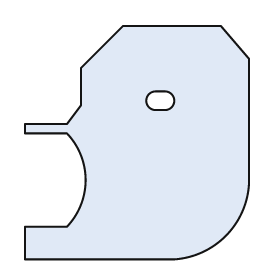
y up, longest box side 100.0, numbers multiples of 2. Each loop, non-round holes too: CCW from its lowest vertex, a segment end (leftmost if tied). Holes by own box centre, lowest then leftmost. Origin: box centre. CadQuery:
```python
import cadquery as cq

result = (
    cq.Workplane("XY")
    .moveTo(-48.0, -50.0)
    .lineTo(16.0, -50.0)
    .threePointArc((38.0, -40.0), (48.0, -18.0))
    .lineTo(48.0, 36.0)
    .lineTo(36.0, 50.0)
    .lineTo(-6.0, 50.0)
    .lineTo(-24.0, 32.0)
    .lineTo(-24.0, 16.0)
    .lineTo(-30.0, 8.0)
    .lineTo(-48.0, 8.0)
    .lineTo(-48.0, 4.0)
    .lineTo(-30.0, 4.0)
    .threePointArc((-22.0, -16.0), (-30.0, -36.0))
    .lineTo(-48.0, -36.0)
    .close()
    .moveTo(8.0, 14.0)
    .lineTo(12.0, 14.0)
    .threePointArc((16.0, 18.0), (12.0, 22.0))
    .lineTo(8.0, 22.0)
    .threePointArc((4.0, 18.0), (8.0, 14.0))
    .close()
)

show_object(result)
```